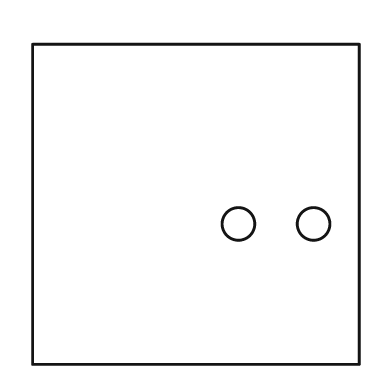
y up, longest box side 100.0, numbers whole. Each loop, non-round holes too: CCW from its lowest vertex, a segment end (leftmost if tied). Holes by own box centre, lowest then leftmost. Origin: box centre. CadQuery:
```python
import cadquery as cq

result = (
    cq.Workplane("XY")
    .moveTo(-50.0, -49.0)
    .lineTo(50.0, -49.0)
    .lineTo(50.0, 49.0)
    .lineTo(-50.0, 49.0)
    .close()
    .moveTo(13.0, -6.0)
    .circle(5.0)
    .moveTo(36.0, -6.0)
    .circle(5.0)
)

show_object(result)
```